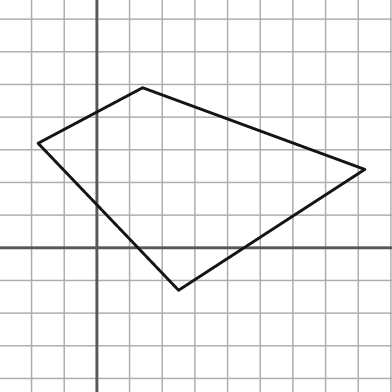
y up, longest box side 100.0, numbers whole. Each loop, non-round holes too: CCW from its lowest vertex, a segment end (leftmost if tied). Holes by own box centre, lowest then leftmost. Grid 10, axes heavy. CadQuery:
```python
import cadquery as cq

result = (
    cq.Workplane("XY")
    .moveTo(25.0, -13.0)
    .lineTo(82.0, 24.0)
    .lineTo(14.0, 49.0)
    .lineTo(-18.0, 32.0)
    .close()
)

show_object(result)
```